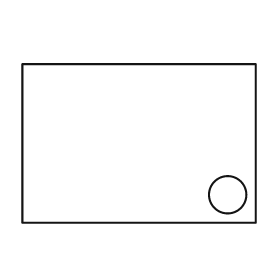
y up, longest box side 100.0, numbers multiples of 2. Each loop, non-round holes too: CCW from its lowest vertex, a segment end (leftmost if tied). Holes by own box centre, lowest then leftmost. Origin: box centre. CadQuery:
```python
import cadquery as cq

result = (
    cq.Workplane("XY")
    .moveTo(-50.0, -34.0)
    .lineTo(50.0, -34.0)
    .lineTo(50.0, 34.0)
    .lineTo(-50.0, 34.0)
    .close()
    .moveTo(38.0, -22.0)
    .circle(8.0)
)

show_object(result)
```